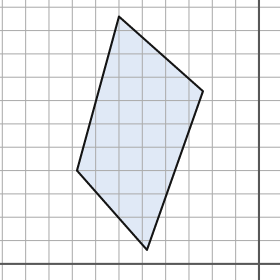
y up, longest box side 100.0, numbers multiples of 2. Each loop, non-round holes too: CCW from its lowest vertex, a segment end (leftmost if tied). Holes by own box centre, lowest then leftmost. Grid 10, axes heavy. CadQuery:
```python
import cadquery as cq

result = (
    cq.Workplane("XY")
    .moveTo(-48.0, 6.0)
    .lineTo(-24.0, 74.0)
    .lineTo(-60.0, 106.0)
    .lineTo(-78.0, 40.0)
    .close()
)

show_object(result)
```